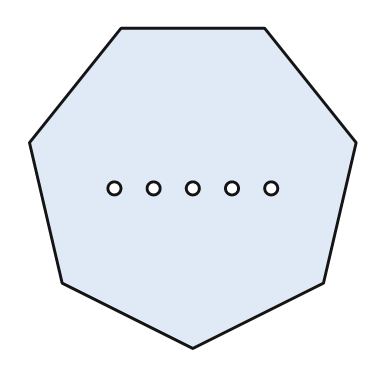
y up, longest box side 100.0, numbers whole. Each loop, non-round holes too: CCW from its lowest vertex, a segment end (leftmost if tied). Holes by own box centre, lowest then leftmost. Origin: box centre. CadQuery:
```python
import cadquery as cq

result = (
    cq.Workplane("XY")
    .moveTo(0.0, -49.0)
    .lineTo(40.0, -29.0)
    .lineTo(50.0, 14.0)
    .lineTo(22.0, 49.0)
    .lineTo(-22.0, 49.0)
    .lineTo(-50.0, 14.0)
    .lineTo(-40.0, -29.0)
    .close()
    .moveTo(-24.0, 0.0)
    .circle(2.0)
    .moveTo(-12.0, 0.0)
    .circle(2.0)
    .moveTo(0.0, 0.0)
    .circle(2.0)
    .moveTo(12.0, 0.0)
    .circle(2.0)
    .moveTo(24.0, 0.0)
    .circle(2.0)
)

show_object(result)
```